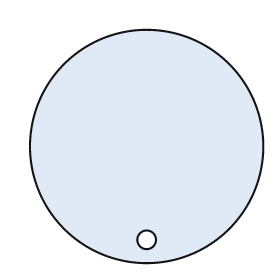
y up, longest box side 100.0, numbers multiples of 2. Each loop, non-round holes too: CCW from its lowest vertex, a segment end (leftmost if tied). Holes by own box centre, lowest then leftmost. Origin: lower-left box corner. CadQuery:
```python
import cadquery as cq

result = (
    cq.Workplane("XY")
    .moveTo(50.0, 50.0)
    .circle(50.0)
    .moveTo(50.0, 10.0)
    .circle(4.0)
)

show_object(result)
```